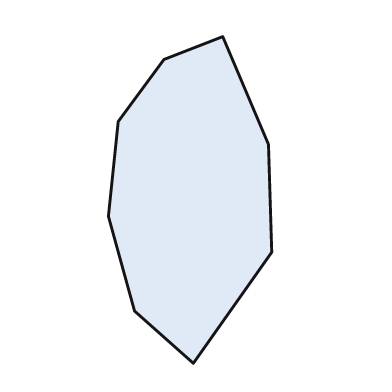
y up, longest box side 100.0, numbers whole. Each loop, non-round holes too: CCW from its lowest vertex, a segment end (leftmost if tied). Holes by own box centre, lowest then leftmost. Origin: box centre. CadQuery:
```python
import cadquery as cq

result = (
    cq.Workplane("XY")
    .moveTo(1.0, -50.0)
    .lineTo(25.0, -16.0)
    .lineTo(24.0, 17.0)
    .lineTo(10.0, 50.0)
    .lineTo(-8.0, 43.0)
    .lineTo(-22.0, 24.0)
    .lineTo(-25.0, -5.0)
    .lineTo(-17.0, -34.0)
    .close()
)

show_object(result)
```